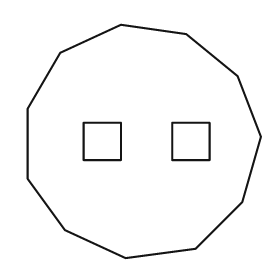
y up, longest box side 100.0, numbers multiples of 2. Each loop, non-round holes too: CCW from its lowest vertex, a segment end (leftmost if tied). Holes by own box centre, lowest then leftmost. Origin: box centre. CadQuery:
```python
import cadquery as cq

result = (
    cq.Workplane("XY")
    .moveTo(-8.0, -50.0)
    .lineTo(22.0, -46.0)
    .lineTo(42.0, -26.0)
    .lineTo(50.0, 2.0)
    .lineTo(40.0, 28.0)
    .lineTo(18.0, 46.0)
    .lineTo(-10.0, 50.0)
    .lineTo(-36.0, 38.0)
    .lineTo(-50.0, 14.0)
    .lineTo(-50.0, -16.0)
    .lineTo(-34.0, -38.0)
    .close()
    .moveTo(-26.0, -8.0)
    .lineTo(-10.0, -8.0)
    .lineTo(-10.0, 8.0)
    .lineTo(-26.0, 8.0)
    .close()
    .moveTo(12.0, -8.0)
    .lineTo(28.0, -8.0)
    .lineTo(28.0, 8.0)
    .lineTo(12.0, 8.0)
    .close()
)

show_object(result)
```